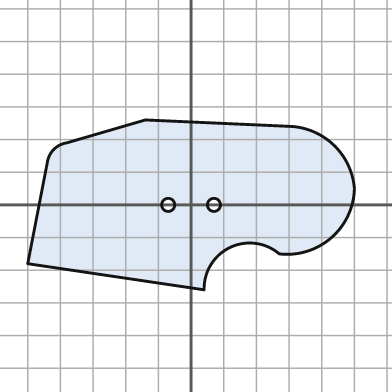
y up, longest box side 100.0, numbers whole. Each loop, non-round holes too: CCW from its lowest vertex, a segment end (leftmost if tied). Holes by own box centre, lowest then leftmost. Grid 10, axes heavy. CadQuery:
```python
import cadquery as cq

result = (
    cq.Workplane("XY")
    .moveTo(4.0, -26.0)
    .threePointArc((12.0, -13.0), (27.0, -15.0))
    .threePointArc((43.0, -10.0), (50.0, 5.0))
    .threePointArc((44.0, 18.0), (31.0, 24.0))
    .lineTo(-14.0, 26.0)
    .lineTo(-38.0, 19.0)
    .threePointArc((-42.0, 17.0), (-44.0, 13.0))
    .lineTo(-50.0, -18.0)
    .close()
    .moveTo(-7.0, 0.0)
    .circle(2.0)
    .moveTo(7.0, 0.0)
    .circle(2.0)
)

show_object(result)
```